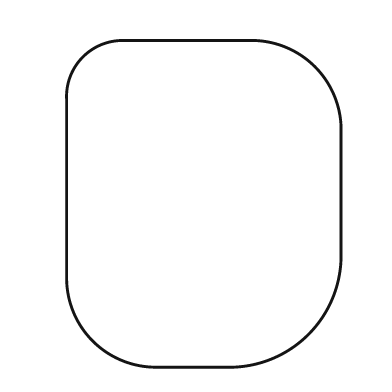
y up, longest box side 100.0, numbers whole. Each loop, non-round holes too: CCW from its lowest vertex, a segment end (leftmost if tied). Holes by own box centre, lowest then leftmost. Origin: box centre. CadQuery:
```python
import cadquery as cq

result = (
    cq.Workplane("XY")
    .moveTo(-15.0, -50.0)
    .lineTo(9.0, -50.0)
    .threePointArc((32.0, -40.0), (42.0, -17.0))
    .lineTo(42.0, 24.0)
    .threePointArc((34.0, 42.0), (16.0, 50.0))
    .lineTo(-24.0, 50.0)
    .threePointArc((-37.0, 45.0), (-42.0, 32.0))
    .lineTo(-42.0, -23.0)
    .threePointArc((-34.0, -42.0), (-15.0, -50.0))
    .close()
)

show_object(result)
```